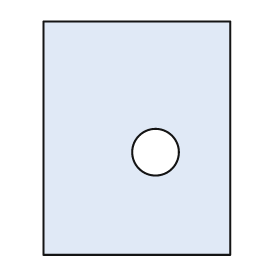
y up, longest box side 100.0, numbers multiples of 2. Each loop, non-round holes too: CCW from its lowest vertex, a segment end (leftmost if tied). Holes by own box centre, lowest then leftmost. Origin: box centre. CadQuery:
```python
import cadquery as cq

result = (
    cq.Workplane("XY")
    .moveTo(-40.0, -50.0)
    .lineTo(40.0, -50.0)
    .lineTo(40.0, 50.0)
    .lineTo(-40.0, 50.0)
    .close()
    .moveTo(8.0, -6.0)
    .circle(10.0)
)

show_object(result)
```